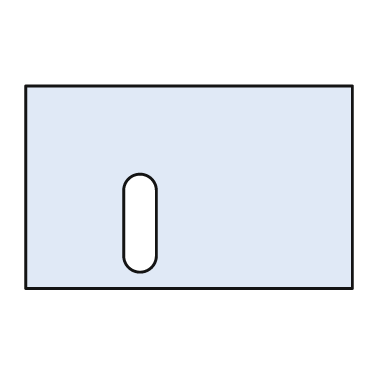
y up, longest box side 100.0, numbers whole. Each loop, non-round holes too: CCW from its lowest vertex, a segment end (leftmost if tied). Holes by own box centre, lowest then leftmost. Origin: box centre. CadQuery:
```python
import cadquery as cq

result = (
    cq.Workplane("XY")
    .moveTo(-50.0, -31.0)
    .lineTo(50.0, -31.0)
    .lineTo(50.0, 31.0)
    .lineTo(-50.0, 31.0)
    .close()
    .moveTo(-20.0, -21.0)
    .threePointArc((-15.0, -26.0), (-10.0, -21.0))
    .lineTo(-10.0, -1.0)
    .threePointArc((-15.0, 4.0), (-20.0, -1.0))
    .close()
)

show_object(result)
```